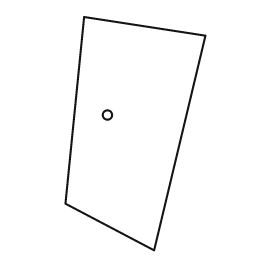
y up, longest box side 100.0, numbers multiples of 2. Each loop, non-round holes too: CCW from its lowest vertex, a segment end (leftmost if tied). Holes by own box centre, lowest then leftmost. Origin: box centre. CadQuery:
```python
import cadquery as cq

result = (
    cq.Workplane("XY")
    .moveTo(8.0, -50.0)
    .lineTo(30.0, 42.0)
    .lineTo(-22.0, 50.0)
    .lineTo(-30.0, -30.0)
    .close()
    .moveTo(-12.0, 8.0)
    .circle(2.0)
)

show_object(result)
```